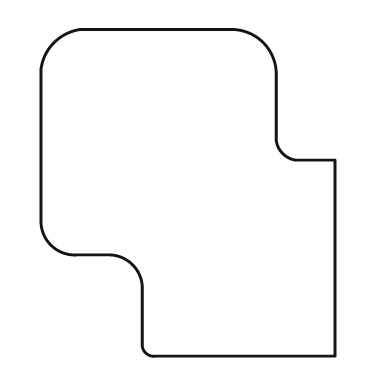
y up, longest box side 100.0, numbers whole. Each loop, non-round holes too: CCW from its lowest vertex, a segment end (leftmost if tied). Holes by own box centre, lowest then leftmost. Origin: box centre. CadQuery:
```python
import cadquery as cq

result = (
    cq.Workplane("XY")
    .moveTo(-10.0, -50.0)
    .lineTo(45.0, -50.0)
    .lineTo(45.0, 10.0)
    .lineTo(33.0, 10.0)
    .threePointArc((29.0, 12.0), (27.0, 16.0))
    .lineTo(27.0, 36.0)
    .threePointArc((23.0, 46.0), (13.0, 50.0))
    .lineTo(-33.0, 50.0)
    .threePointArc((-41.0, 46.0), (-45.0, 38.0))
    .lineTo(-45.0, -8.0)
    .threePointArc((-42.0, -16.0), (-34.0, -19.0))
    .lineTo(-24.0, -19.0)
    .threePointArc((-17.0, -22.0), (-14.0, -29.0))
    .lineTo(-14.0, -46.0)
    .threePointArc((-13.0, -49.0), (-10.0, -50.0))
    .close()
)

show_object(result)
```